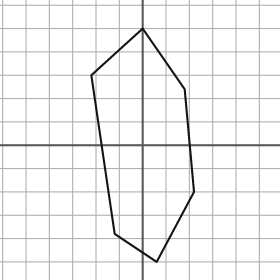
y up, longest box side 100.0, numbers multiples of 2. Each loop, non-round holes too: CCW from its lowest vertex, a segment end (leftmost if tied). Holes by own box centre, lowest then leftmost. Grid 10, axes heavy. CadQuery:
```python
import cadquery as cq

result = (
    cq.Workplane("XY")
    .moveTo(6.0, -50.0)
    .lineTo(22.0, -20.0)
    .lineTo(18.0, 24.0)
    .lineTo(0.0, 50.0)
    .lineTo(-22.0, 30.0)
    .lineTo(-12.0, -38.0)
    .close()
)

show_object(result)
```